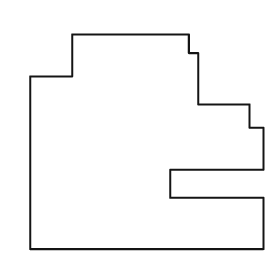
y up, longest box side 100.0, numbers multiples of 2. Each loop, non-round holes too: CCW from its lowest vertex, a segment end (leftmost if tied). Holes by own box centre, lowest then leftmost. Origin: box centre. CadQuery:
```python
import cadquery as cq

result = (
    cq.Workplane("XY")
    .moveTo(-50.0, -46.0)
    .lineTo(50.0, -46.0)
    .lineTo(50.0, -24.0)
    .lineTo(10.0, -24.0)
    .lineTo(10.0, -12.0)
    .lineTo(50.0, -12.0)
    .lineTo(50.0, 6.0)
    .lineTo(44.0, 6.0)
    .lineTo(44.0, 16.0)
    .lineTo(22.0, 16.0)
    .lineTo(22.0, 38.0)
    .lineTo(18.0, 38.0)
    .lineTo(18.0, 46.0)
    .lineTo(-32.0, 46.0)
    .lineTo(-32.0, 28.0)
    .lineTo(-50.0, 28.0)
    .close()
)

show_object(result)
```